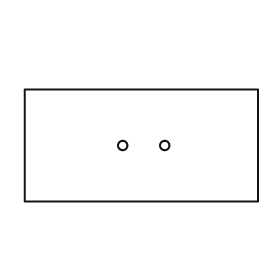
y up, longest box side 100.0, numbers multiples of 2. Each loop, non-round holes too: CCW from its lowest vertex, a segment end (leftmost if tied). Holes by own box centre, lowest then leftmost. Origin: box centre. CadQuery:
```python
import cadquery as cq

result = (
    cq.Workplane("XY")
    .moveTo(-50.0, -24.0)
    .lineTo(50.0, -24.0)
    .lineTo(50.0, 24.0)
    .lineTo(-50.0, 24.0)
    .close()
    .moveTo(-8.0, 0.0)
    .circle(2.0)
    .moveTo(10.0, 0.0)
    .circle(2.0)
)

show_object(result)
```